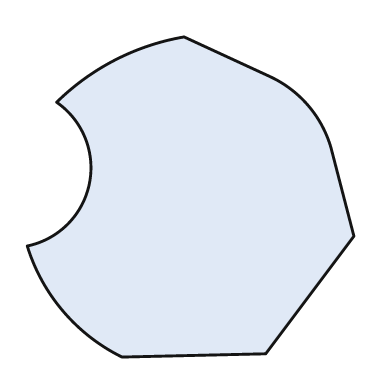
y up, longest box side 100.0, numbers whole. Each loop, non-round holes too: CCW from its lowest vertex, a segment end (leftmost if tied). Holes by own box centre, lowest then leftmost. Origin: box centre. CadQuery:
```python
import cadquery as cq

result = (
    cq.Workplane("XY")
    .moveTo(-21.0, -49.0)
    .lineTo(23.0, -48.0)
    .lineTo(50.0, -12.0)
    .lineTo(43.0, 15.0)
    .threePointArc((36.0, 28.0), (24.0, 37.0))
    .lineTo(-2.0, 49.0)
    .threePointArc((-23.0, 42.0), (-41.0, 29.0))
    .threePointArc((-31.0, 4.0), (-50.0, -15.0))
    .threePointArc((-39.0, -35.0), (-21.0, -49.0))
    .close()
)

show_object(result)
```